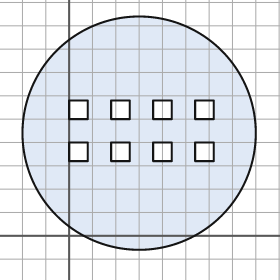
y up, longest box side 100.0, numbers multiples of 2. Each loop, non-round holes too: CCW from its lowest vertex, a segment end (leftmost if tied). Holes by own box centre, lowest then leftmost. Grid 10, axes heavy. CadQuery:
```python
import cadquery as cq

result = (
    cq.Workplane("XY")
    .moveTo(30.0, 44.0)
    .circle(50.0)
    .moveTo(0.0, 32.0)
    .lineTo(8.0, 32.0)
    .lineTo(8.0, 40.0)
    .lineTo(0.0, 40.0)
    .close()
    .moveTo(18.0, 32.0)
    .lineTo(26.0, 32.0)
    .lineTo(26.0, 40.0)
    .lineTo(18.0, 40.0)
    .close()
    .moveTo(36.0, 32.0)
    .lineTo(44.0, 32.0)
    .lineTo(44.0, 40.0)
    .lineTo(36.0, 40.0)
    .close()
    .moveTo(54.0, 32.0)
    .lineTo(62.0, 32.0)
    .lineTo(62.0, 40.0)
    .lineTo(54.0, 40.0)
    .close()
    .moveTo(0.0, 50.0)
    .lineTo(8.0, 50.0)
    .lineTo(8.0, 58.0)
    .lineTo(0.0, 58.0)
    .close()
    .moveTo(18.0, 50.0)
    .lineTo(26.0, 50.0)
    .lineTo(26.0, 58.0)
    .lineTo(18.0, 58.0)
    .close()
    .moveTo(36.0, 50.0)
    .lineTo(44.0, 50.0)
    .lineTo(44.0, 58.0)
    .lineTo(36.0, 58.0)
    .close()
    .moveTo(54.0, 50.0)
    .lineTo(62.0, 50.0)
    .lineTo(62.0, 58.0)
    .lineTo(54.0, 58.0)
    .close()
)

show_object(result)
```